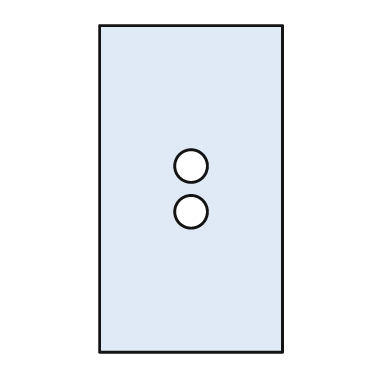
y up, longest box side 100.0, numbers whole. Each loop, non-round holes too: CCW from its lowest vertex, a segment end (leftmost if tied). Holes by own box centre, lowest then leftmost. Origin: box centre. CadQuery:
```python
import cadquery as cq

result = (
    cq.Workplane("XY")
    .moveTo(-28.0, -50.0)
    .lineTo(28.0, -50.0)
    .lineTo(28.0, 50.0)
    .lineTo(-28.0, 50.0)
    .close()
    .moveTo(0.0, -7.0)
    .circle(5.0)
    .moveTo(0.0, 7.0)
    .circle(5.0)
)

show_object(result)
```